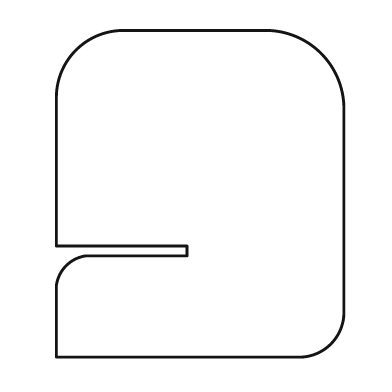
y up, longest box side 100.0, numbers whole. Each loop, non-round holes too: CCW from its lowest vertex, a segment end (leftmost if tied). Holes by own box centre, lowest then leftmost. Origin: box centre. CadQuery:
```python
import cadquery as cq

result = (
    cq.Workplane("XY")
    .moveTo(-44.0, -50.0)
    .lineTo(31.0, -50.0)
    .threePointArc((40.0, -46.0), (44.0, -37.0))
    .lineTo(44.0, 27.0)
    .threePointArc((37.0, 43.0), (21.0, 50.0))
    .lineTo(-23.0, 50.0)
    .threePointArc((-38.0, 44.0), (-44.0, 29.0))
    .lineTo(-44.0, -16.0)
    .lineTo(-4.0, -16.0)
    .lineTo(-4.0, -19.0)
    .lineTo(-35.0, -19.0)
    .threePointArc((-41.0, -22.0), (-44.0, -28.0))
    .close()
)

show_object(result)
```